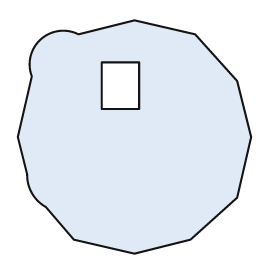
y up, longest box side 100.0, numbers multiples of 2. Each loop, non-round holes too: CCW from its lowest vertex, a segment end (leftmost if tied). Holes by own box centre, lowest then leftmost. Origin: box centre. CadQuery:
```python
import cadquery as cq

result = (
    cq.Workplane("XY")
    .moveTo(0.0, -50.0)
    .lineTo(24.0, -44.0)
    .lineTo(44.0, -26.0)
    .lineTo(50.0, 0.0)
    .lineTo(44.0, 24.0)
    .lineTo(26.0, 44.0)
    .lineTo(0.0, 50.0)
    .lineTo(-24.0, 44.0)
    .threePointArc((-40.0, 42.0), (-44.0, 26.0))
    .lineTo(-50.0, 0.0)
    .lineTo(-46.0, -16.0)
    .threePointArc((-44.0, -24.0), (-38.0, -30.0))
    .lineTo(-26.0, -44.0)
    .close()
    .moveTo(-14.0, 12.0)
    .lineTo(2.0, 12.0)
    .lineTo(2.0, 32.0)
    .lineTo(-14.0, 32.0)
    .close()
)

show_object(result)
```